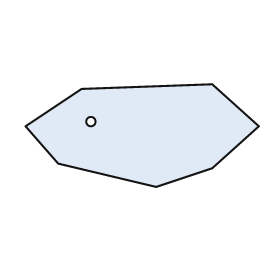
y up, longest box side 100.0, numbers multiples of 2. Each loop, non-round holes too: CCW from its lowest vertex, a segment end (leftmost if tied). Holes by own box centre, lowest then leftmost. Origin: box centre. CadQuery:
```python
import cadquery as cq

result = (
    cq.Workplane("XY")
    .moveTo(6.0, -22.0)
    .lineTo(30.0, -14.0)
    .lineTo(50.0, 4.0)
    .lineTo(30.0, 22.0)
    .lineTo(-26.0, 20.0)
    .lineTo(-50.0, 4.0)
    .lineTo(-36.0, -12.0)
    .close()
    .moveTo(-22.0, 6.0)
    .circle(2.0)
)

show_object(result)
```